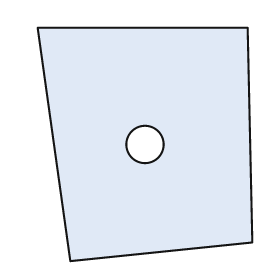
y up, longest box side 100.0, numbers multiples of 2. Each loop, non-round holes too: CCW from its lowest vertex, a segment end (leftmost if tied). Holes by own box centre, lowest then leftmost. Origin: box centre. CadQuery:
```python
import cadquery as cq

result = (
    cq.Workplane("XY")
    .moveTo(-32.0, -50.0)
    .lineTo(46.0, -42.0)
    .lineTo(44.0, 50.0)
    .lineTo(-46.0, 50.0)
    .close()
    .moveTo(0.0, 0.0)
    .circle(8.0)
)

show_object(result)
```